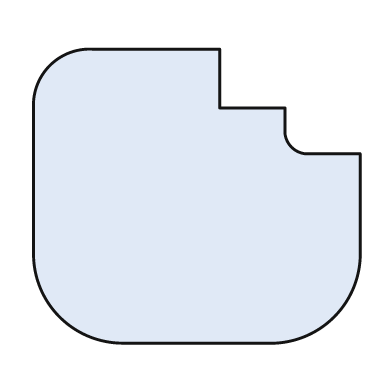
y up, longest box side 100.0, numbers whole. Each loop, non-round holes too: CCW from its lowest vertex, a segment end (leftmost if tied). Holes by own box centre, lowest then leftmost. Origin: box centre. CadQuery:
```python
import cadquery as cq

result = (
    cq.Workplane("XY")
    .moveTo(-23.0, -45.0)
    .lineTo(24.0, -45.0)
    .threePointArc((42.0, -37.0), (50.0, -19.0))
    .lineTo(50.0, 13.0)
    .lineTo(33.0, 13.0)
    .threePointArc((29.0, 15.0), (27.0, 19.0))
    .lineTo(27.0, 27.0)
    .lineTo(7.0, 27.0)
    .lineTo(7.0, 45.0)
    .lineTo(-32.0, 45.0)
    .threePointArc((-45.0, 40.0), (-50.0, 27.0))
    .lineTo(-50.0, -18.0)
    .threePointArc((-42.0, -37.0), (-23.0, -45.0))
    .close()
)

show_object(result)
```